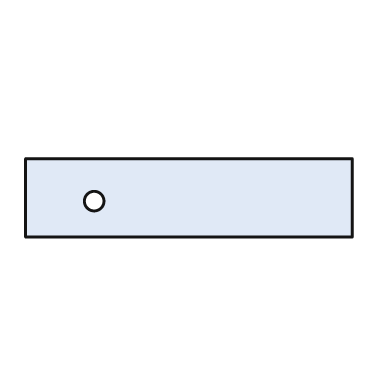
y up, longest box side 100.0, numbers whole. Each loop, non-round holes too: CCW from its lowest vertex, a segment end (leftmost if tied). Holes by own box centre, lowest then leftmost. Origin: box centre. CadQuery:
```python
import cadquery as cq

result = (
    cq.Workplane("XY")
    .moveTo(-50.0, -12.0)
    .lineTo(50.0, -12.0)
    .lineTo(50.0, 12.0)
    .lineTo(-50.0, 12.0)
    .close()
    .moveTo(-29.0, -1.0)
    .circle(3.0)
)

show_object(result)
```